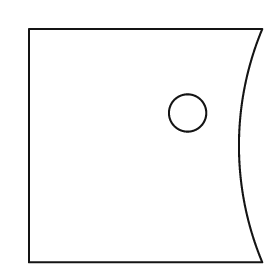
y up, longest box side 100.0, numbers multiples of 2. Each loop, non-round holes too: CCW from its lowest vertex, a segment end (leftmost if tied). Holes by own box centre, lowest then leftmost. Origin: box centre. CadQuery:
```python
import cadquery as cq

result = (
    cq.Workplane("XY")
    .moveTo(-50.0, -50.0)
    .lineTo(50.0, -50.0)
    .threePointArc((40.0, 0.0), (50.0, 50.0))
    .lineTo(-50.0, 50.0)
    .close()
    .moveTo(18.0, 14.0)
    .circle(8.0)
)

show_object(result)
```